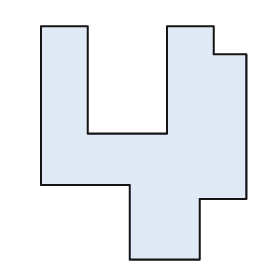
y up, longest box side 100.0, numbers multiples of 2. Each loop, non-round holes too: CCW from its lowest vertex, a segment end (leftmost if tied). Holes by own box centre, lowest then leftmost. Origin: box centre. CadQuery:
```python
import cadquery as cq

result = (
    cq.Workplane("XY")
    .moveTo(-6.0, -50.0)
    .lineTo(24.0, -50.0)
    .lineTo(24.0, -24.0)
    .lineTo(44.0, -24.0)
    .lineTo(44.0, 38.0)
    .lineTo(30.0, 38.0)
    .lineTo(30.0, 50.0)
    .lineTo(10.0, 50.0)
    .lineTo(10.0, 4.0)
    .lineTo(-24.0, 4.0)
    .lineTo(-24.0, 50.0)
    .lineTo(-44.0, 50.0)
    .lineTo(-44.0, -18.0)
    .lineTo(-6.0, -18.0)
    .close()
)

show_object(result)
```